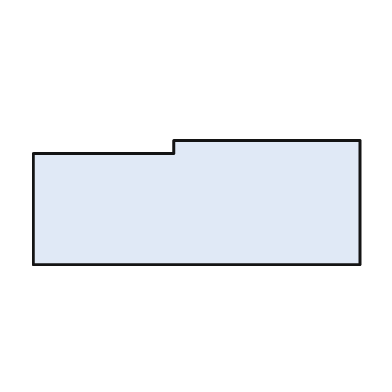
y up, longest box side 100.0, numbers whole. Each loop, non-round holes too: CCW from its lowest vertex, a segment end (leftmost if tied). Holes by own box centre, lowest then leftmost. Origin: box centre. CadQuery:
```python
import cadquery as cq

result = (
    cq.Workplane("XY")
    .moveTo(-50.0, -19.0)
    .lineTo(50.0, -19.0)
    .lineTo(50.0, 19.0)
    .lineTo(-7.0, 19.0)
    .lineTo(-7.0, 15.0)
    .lineTo(-50.0, 15.0)
    .close()
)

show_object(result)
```